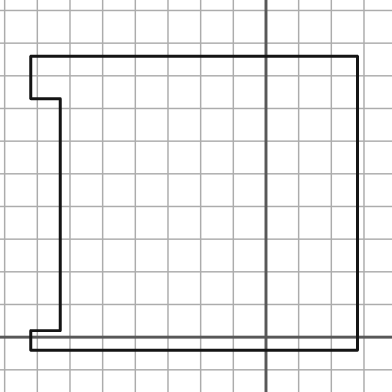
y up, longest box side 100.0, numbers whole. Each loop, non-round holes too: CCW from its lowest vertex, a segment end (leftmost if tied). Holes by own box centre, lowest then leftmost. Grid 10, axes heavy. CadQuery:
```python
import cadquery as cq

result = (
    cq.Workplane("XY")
    .moveTo(-72.0, -4.0)
    .lineTo(28.0, -4.0)
    .lineTo(28.0, 86.0)
    .lineTo(-72.0, 86.0)
    .lineTo(-72.0, 73.0)
    .lineTo(-63.0, 73.0)
    .lineTo(-63.0, 2.0)
    .lineTo(-72.0, 2.0)
    .close()
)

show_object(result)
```